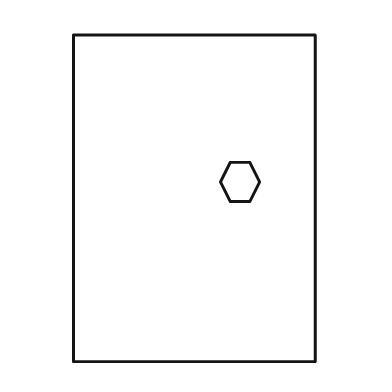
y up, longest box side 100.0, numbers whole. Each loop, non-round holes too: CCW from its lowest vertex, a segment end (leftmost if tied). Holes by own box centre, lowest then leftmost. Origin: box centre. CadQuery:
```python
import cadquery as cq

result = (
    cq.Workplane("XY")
    .moveTo(-37.0, -50.0)
    .lineTo(37.0, -50.0)
    .lineTo(37.0, 50.0)
    .lineTo(-37.0, 50.0)
    .close()
    .moveTo(11.0, -1.0)
    .lineTo(17.0, -1.0)
    .lineTo(20.0, 5.0)
    .lineTo(17.0, 11.0)
    .lineTo(11.0, 11.0)
    .lineTo(8.0, 5.0)
    .close()
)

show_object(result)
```